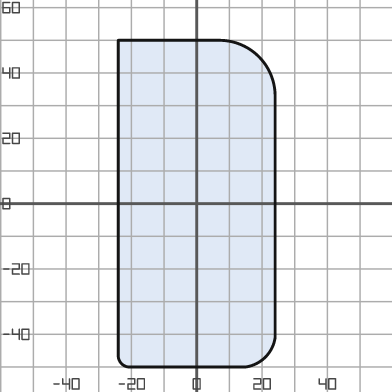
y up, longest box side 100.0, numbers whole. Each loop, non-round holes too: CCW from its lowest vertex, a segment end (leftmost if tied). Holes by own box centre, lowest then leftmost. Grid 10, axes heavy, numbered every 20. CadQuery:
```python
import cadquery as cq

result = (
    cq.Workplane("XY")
    .moveTo(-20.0, -50.0)
    .lineTo(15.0, -50.0)
    .threePointArc((21.0, -47.0), (24.0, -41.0))
    .lineTo(24.0, 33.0)
    .threePointArc((19.0, 45.0), (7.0, 50.0))
    .lineTo(-24.0, 50.0)
    .lineTo(-24.0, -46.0)
    .threePointArc((-23.0, -49.0), (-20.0, -50.0))
    .close()
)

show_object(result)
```